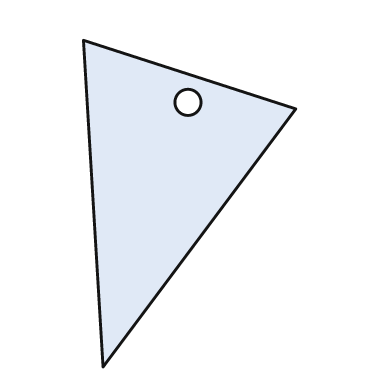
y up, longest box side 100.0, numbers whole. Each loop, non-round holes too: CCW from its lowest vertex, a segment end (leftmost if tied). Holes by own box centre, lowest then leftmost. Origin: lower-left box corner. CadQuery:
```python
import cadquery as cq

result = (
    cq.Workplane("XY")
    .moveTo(6.0, 0.0)
    .lineTo(65.0, 79.0)
    .lineTo(0.0, 100.0)
    .close()
    .moveTo(32.0, 81.0)
    .circle(4.0)
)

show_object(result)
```